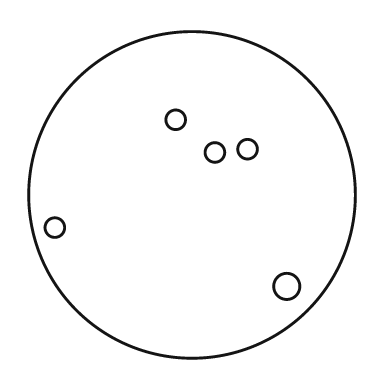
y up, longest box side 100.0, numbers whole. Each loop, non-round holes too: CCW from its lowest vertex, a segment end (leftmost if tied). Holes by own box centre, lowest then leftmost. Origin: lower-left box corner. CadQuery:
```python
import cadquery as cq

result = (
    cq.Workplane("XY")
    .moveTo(50.0, 50.0)
    .circle(50.0)
    .moveTo(79.0, 22.0)
    .circle(4.0)
    .moveTo(8.0, 40.0)
    .circle(3.0)
    .moveTo(57.0, 63.0)
    .circle(3.0)
    .moveTo(67.0, 64.0)
    .circle(3.0)
    .moveTo(45.0, 73.0)
    .circle(3.0)
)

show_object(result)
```